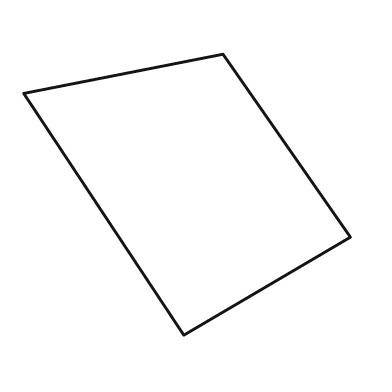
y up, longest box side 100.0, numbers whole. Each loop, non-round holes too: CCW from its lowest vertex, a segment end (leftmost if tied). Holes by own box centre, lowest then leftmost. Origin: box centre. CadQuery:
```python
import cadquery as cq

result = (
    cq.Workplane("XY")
    .moveTo(-1.0, -43.0)
    .lineTo(50.0, -13.0)
    .lineTo(11.0, 43.0)
    .lineTo(-50.0, 31.0)
    .close()
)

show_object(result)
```